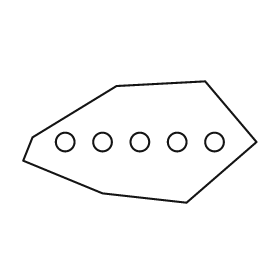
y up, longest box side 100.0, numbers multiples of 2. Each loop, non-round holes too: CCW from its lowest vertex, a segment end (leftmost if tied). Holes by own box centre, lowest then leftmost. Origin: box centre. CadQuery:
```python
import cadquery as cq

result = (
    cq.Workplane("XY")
    .moveTo(20.0, -26.0)
    .lineTo(50.0, 0.0)
    .lineTo(28.0, 26.0)
    .lineTo(-10.0, 24.0)
    .lineTo(-46.0, 2.0)
    .lineTo(-50.0, -8.0)
    .lineTo(-16.0, -22.0)
    .close()
    .moveTo(-32.0, 0.0)
    .circle(4.0)
    .moveTo(-16.0, 0.0)
    .circle(4.0)
    .moveTo(0.0, 0.0)
    .circle(4.0)
    .moveTo(16.0, 0.0)
    .circle(4.0)
    .moveTo(32.0, 0.0)
    .circle(4.0)
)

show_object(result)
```